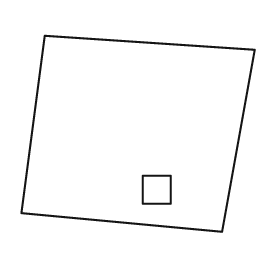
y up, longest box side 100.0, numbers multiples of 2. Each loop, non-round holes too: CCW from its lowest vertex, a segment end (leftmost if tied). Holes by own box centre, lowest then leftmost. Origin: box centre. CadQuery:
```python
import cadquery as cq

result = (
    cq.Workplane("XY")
    .moveTo(36.0, -42.0)
    .lineTo(50.0, 36.0)
    .lineTo(-40.0, 42.0)
    .lineTo(-50.0, -34.0)
    .close()
    .moveTo(2.0, -30.0)
    .lineTo(14.0, -30.0)
    .lineTo(14.0, -18.0)
    .lineTo(2.0, -18.0)
    .close()
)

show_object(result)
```